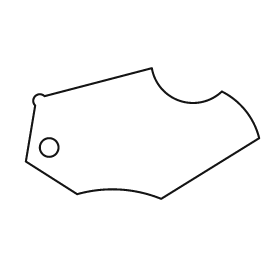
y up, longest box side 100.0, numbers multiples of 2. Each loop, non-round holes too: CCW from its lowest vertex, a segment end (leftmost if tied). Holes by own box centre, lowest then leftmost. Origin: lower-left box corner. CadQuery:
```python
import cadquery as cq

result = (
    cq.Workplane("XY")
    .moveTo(58.0, 0.0)
    .lineTo(100.0, 26.0)
    .threePointArc((94.0, 38.0), (84.0, 46.0))
    .threePointArc((66.0, 42.0), (54.0, 56.0))
    .lineTo(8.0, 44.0)
    .threePointArc((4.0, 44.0), (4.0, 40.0))
    .lineTo(0.0, 16.0)
    .lineTo(22.0, 2.0)
    .threePointArc((40.0, 4.0), (58.0, 0.0))
    .close()
    .moveTo(10.0, 22.0)
    .circle(4.0)
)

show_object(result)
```